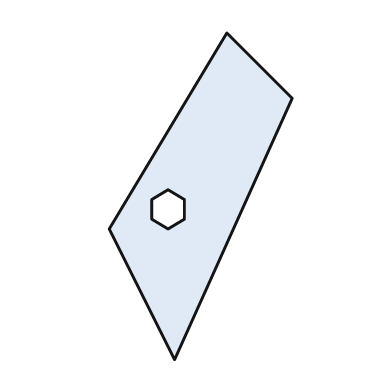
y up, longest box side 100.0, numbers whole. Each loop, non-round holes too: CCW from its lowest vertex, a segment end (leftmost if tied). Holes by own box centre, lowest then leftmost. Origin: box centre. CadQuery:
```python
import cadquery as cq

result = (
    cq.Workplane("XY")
    .moveTo(-8.0, -50.0)
    .lineTo(28.0, 30.0)
    .lineTo(8.0, 50.0)
    .lineTo(-28.0, -10.0)
    .close()
    .moveTo(-10.0, -10.0)
    .lineTo(-5.0, -7.0)
    .lineTo(-5.0, -1.0)
    .lineTo(-10.0, 2.0)
    .lineTo(-15.0, -1.0)
    .lineTo(-15.0, -7.0)
    .close()
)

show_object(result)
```